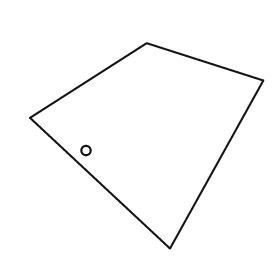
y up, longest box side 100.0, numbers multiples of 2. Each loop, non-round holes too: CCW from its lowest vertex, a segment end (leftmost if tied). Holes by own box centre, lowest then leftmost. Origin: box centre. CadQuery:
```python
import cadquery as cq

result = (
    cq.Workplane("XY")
    .moveTo(10.0, -44.0)
    .lineTo(50.0, 28.0)
    .lineTo(0.0, 44.0)
    .lineTo(-50.0, 12.0)
    .close()
    .moveTo(-26.0, -2.0)
    .circle(2.0)
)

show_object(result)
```